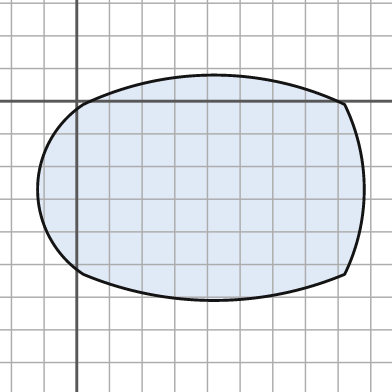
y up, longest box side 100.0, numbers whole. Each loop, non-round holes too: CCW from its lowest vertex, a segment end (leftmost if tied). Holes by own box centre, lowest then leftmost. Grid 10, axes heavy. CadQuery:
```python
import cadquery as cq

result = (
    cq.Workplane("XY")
    .moveTo(2.0, -53.0)
    .threePointArc((42.0, -61.0), (82.0, -53.0))
    .threePointArc((88.0, -27.0), (82.0, -1.0))
    .threePointArc((42.0, 8.0), (2.0, -1.0))
    .threePointArc((-12.0, -27.0), (2.0, -53.0))
    .close()
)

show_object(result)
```